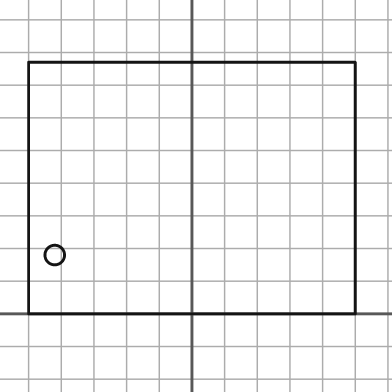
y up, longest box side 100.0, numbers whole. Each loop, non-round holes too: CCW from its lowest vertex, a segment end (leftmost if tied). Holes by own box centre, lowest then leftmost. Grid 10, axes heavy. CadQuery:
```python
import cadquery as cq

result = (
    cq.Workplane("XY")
    .moveTo(-50.0, 0.0)
    .lineTo(50.0, 0.0)
    .lineTo(50.0, 77.0)
    .lineTo(-50.0, 77.0)
    .close()
    .moveTo(-42.0, 18.0)
    .circle(3.0)
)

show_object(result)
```